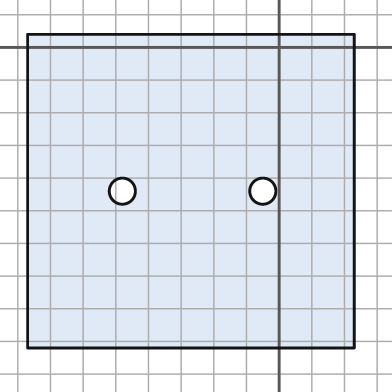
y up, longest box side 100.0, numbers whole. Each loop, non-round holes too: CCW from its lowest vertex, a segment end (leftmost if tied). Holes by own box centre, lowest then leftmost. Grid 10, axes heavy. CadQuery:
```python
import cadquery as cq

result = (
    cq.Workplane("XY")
    .moveTo(-77.0, -92.0)
    .lineTo(23.0, -92.0)
    .lineTo(23.0, 4.0)
    .lineTo(-77.0, 4.0)
    .close()
    .moveTo(-48.0, -44.0)
    .circle(4.0)
    .moveTo(-5.0, -44.0)
    .circle(4.0)
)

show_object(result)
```